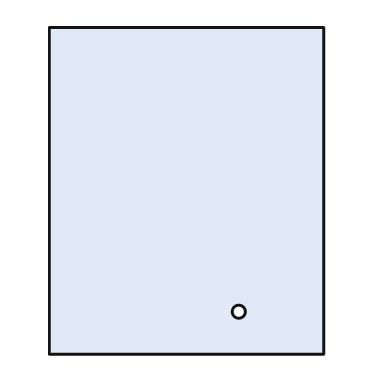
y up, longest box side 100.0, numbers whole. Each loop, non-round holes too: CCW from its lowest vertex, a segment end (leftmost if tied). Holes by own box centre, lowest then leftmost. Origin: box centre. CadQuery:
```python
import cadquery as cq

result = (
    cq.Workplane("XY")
    .moveTo(-42.0, -50.0)
    .lineTo(42.0, -50.0)
    .lineTo(42.0, 50.0)
    .lineTo(-42.0, 50.0)
    .close()
    .moveTo(16.0, -37.0)
    .circle(2.0)
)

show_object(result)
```